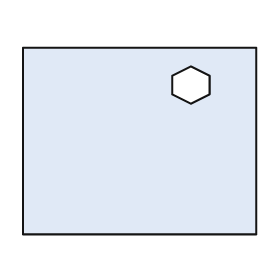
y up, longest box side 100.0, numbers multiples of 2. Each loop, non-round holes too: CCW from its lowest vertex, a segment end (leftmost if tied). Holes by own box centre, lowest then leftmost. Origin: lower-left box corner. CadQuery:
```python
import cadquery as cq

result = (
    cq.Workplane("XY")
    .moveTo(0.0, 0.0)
    .lineTo(100.0, 0.0)
    .lineTo(100.0, 80.0)
    .lineTo(0.0, 80.0)
    .close()
    .moveTo(72.0, 56.0)
    .lineTo(80.0, 60.0)
    .lineTo(80.0, 68.0)
    .lineTo(72.0, 72.0)
    .lineTo(64.0, 68.0)
    .lineTo(64.0, 60.0)
    .close()
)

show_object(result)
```